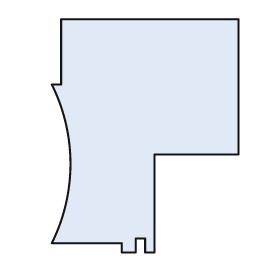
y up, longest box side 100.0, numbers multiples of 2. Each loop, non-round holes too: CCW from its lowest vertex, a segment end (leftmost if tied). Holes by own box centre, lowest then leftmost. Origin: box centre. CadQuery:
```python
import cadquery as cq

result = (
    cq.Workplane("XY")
    .moveTo(-10.0, -50.0)
    .lineTo(-4.0, -50.0)
    .lineTo(-4.0, -44.0)
    .lineTo(0.0, -44.0)
    .lineTo(0.0, -50.0)
    .lineTo(4.0, -50.0)
    .lineTo(4.0, -8.0)
    .lineTo(40.0, -8.0)
    .lineTo(40.0, 50.0)
    .lineTo(-36.0, 50.0)
    .lineTo(-36.0, 22.0)
    .lineTo(-40.0, 22.0)
    .threePointArc((-32.0, -12.0), (-40.0, -46.0))
    .lineTo(-10.0, -46.0)
    .close()
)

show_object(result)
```